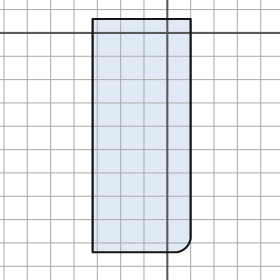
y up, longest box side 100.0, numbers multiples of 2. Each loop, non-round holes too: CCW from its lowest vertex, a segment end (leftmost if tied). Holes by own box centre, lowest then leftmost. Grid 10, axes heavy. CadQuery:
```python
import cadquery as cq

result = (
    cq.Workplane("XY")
    .moveTo(-32.0, -94.0)
    .lineTo(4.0, -94.0)
    .threePointArc((8.0, -92.0), (10.0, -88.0))
    .lineTo(10.0, 6.0)
    .lineTo(-32.0, 6.0)
    .close()
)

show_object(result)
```